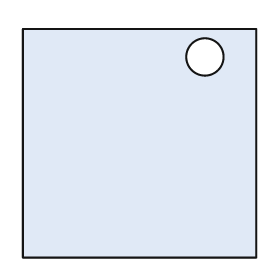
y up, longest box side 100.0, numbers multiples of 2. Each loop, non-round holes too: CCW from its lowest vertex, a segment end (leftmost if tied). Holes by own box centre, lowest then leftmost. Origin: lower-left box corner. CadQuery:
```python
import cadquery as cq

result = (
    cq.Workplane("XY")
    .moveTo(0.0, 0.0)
    .lineTo(100.0, 0.0)
    .lineTo(100.0, 98.0)
    .lineTo(0.0, 98.0)
    .close()
    .moveTo(78.0, 86.0)
    .circle(8.0)
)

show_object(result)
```